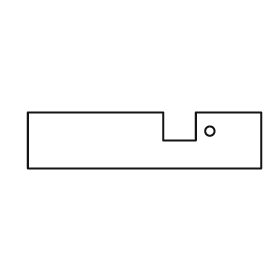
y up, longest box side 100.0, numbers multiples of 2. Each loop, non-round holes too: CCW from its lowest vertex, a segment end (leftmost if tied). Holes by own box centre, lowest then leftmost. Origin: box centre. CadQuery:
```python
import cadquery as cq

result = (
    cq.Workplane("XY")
    .moveTo(-50.0, -12.0)
    .lineTo(50.0, -12.0)
    .lineTo(50.0, 12.0)
    .lineTo(22.0, 12.0)
    .lineTo(22.0, 0.0)
    .lineTo(8.0, 0.0)
    .lineTo(8.0, 12.0)
    .lineTo(-50.0, 12.0)
    .close()
    .moveTo(28.0, 4.0)
    .circle(2.0)
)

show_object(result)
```